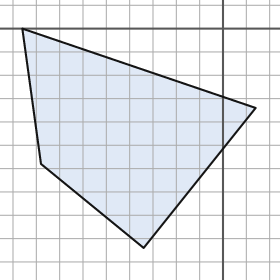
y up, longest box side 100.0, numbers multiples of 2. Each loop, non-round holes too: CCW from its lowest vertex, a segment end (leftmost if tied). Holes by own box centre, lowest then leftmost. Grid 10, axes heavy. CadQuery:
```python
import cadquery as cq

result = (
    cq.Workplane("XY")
    .moveTo(-34.0, -94.0)
    .lineTo(14.0, -34.0)
    .lineTo(-86.0, 0.0)
    .lineTo(-78.0, -58.0)
    .close()
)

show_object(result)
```